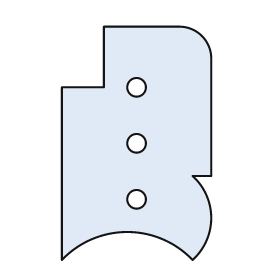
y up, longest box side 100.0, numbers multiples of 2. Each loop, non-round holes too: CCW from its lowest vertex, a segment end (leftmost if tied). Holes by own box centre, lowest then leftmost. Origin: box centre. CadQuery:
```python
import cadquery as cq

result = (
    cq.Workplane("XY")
    .moveTo(-32.0, -50.0)
    .threePointArc((-4.0, -38.0), (24.0, -50.0))
    .threePointArc((32.0, -32.0), (24.0, -14.0))
    .lineTo(32.0, -14.0)
    .lineTo(32.0, 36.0)
    .threePointArc((28.0, 46.0), (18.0, 50.0))
    .lineTo(-14.0, 50.0)
    .lineTo(-14.0, 24.0)
    .lineTo(-32.0, 24.0)
    .close()
    .moveTo(0.0, -24.0)
    .circle(4.0)
    .moveTo(0.0, 0.0)
    .circle(4.0)
    .moveTo(0.0, 24.0)
    .circle(4.0)
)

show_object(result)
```